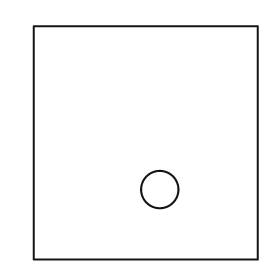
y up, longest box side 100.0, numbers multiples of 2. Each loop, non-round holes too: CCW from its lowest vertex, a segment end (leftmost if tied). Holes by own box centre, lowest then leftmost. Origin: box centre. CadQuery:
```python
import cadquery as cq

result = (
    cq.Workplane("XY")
    .moveTo(-48.0, -50.0)
    .lineTo(48.0, -50.0)
    .lineTo(48.0, 50.0)
    .lineTo(-48.0, 50.0)
    .close()
    .moveTo(6.0, -20.0)
    .circle(8.0)
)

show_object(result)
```